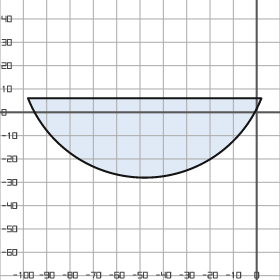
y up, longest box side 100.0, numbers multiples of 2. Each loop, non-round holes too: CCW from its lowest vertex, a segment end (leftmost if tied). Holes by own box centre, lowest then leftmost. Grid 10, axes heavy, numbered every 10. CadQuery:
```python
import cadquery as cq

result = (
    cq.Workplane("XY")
    .moveTo(-98.0, 6.0)
    .threePointArc((-48.0, -28.0), (2.0, 6.0))
    .close()
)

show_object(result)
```